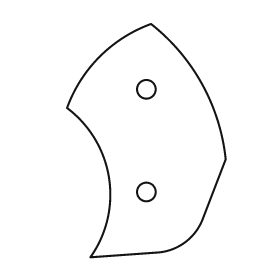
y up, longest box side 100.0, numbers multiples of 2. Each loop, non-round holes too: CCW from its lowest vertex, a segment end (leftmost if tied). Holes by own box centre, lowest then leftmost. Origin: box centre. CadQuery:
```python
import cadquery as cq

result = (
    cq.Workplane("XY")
    .moveTo(-24.0, -50.0)
    .lineTo(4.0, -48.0)
    .threePointArc((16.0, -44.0), (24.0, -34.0))
    .lineTo(34.0, -8.0)
    .threePointArc((24.0, 24.0), (2.0, 50.0))
    .threePointArc((-20.0, 36.0), (-34.0, 14.0))
    .threePointArc((-16.0, -16.0), (-24.0, -50.0))
    .close()
    .moveTo(0.0, -22.0)
    .circle(4.0)
    .moveTo(0.0, 22.0)
    .circle(4.0)
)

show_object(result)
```